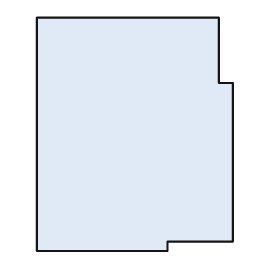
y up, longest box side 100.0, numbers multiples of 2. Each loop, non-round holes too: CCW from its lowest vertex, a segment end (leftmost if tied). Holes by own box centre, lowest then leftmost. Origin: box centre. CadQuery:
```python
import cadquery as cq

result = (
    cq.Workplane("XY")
    .moveTo(-42.0, -50.0)
    .lineTo(14.0, -50.0)
    .lineTo(14.0, -46.0)
    .lineTo(42.0, -46.0)
    .lineTo(42.0, 22.0)
    .lineTo(36.0, 22.0)
    .lineTo(36.0, 50.0)
    .lineTo(-42.0, 50.0)
    .close()
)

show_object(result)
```